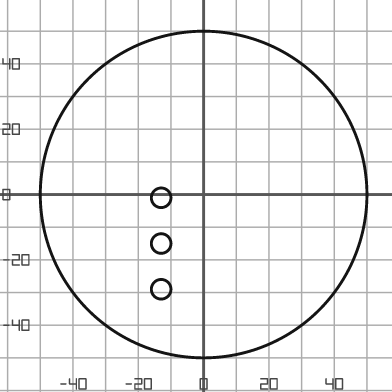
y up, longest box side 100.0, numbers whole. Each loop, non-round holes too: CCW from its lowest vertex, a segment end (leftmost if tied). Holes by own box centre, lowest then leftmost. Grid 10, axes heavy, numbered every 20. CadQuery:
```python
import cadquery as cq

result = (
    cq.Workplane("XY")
    .moveTo(0.0, 0.0)
    .circle(50.0)
    .moveTo(-13.0, -29.0)
    .circle(3.0)
    .moveTo(-13.0, -15.0)
    .circle(3.0)
    .moveTo(-13.0, -1.0)
    .circle(3.0)
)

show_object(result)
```